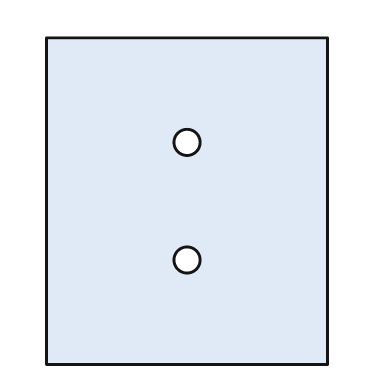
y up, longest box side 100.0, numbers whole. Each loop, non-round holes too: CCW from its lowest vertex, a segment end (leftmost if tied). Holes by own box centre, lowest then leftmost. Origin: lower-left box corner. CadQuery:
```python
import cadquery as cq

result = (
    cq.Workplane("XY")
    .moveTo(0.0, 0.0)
    .lineTo(86.0, 0.0)
    .lineTo(86.0, 100.0)
    .lineTo(0.0, 100.0)
    .close()
    .moveTo(43.0, 32.0)
    .circle(4.0)
    .moveTo(43.0, 68.0)
    .circle(4.0)
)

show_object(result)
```